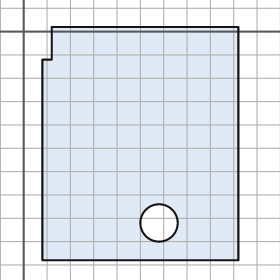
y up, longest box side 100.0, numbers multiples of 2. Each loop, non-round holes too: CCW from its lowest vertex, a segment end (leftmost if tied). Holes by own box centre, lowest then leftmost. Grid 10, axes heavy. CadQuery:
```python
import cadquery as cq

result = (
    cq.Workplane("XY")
    .moveTo(8.0, -98.0)
    .lineTo(92.0, -98.0)
    .lineTo(92.0, 2.0)
    .lineTo(12.0, 2.0)
    .lineTo(12.0, -12.0)
    .lineTo(8.0, -12.0)
    .close()
    .moveTo(58.0, -82.0)
    .circle(8.0)
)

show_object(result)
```